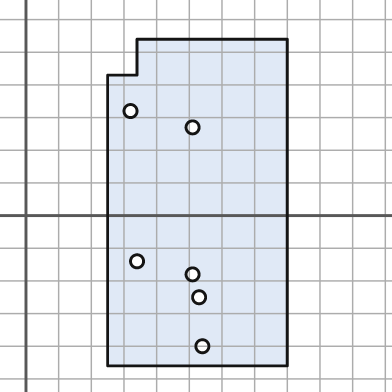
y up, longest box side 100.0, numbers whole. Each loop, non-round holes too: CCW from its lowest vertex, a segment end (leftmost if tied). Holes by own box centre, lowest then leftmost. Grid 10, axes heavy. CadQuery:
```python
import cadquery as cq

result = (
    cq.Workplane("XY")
    .moveTo(25.0, -46.0)
    .lineTo(80.0, -46.0)
    .lineTo(80.0, 54.0)
    .lineTo(34.0, 54.0)
    .lineTo(34.0, 43.0)
    .lineTo(25.0, 43.0)
    .close()
    .moveTo(54.0, -40.0)
    .circle(2.0)
    .moveTo(53.0, -25.0)
    .circle(2.0)
    .moveTo(51.0, -18.0)
    .circle(2.0)
    .moveTo(34.0, -14.0)
    .circle(2.0)
    .moveTo(51.0, 27.0)
    .circle(2.0)
    .moveTo(32.0, 32.0)
    .circle(2.0)
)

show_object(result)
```